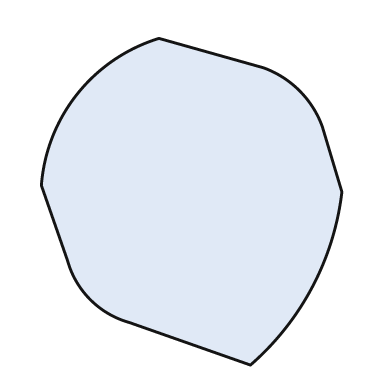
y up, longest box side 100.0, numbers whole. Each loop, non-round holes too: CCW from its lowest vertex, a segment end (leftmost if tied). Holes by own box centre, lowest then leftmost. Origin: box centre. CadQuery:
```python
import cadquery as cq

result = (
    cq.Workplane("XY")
    .moveTo(18.0, -50.0)
    .threePointArc((37.0, -26.0), (46.0, 3.0))
    .lineTo(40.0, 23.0)
    .threePointArc((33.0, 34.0), (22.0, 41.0))
    .lineTo(-10.0, 50.0)
    .threePointArc((-35.0, 33.0), (-46.0, 5.0))
    .lineTo(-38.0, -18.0)
    .threePointArc((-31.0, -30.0), (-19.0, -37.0))
    .close()
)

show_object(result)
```